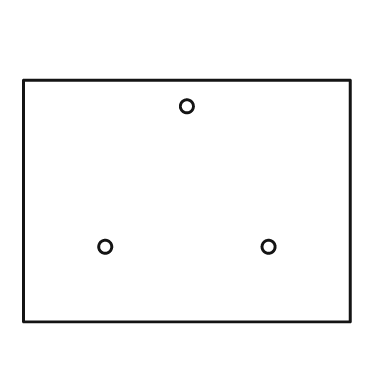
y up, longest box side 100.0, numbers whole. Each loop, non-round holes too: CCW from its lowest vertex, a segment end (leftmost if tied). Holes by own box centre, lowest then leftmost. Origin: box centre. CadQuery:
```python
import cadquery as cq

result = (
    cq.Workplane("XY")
    .moveTo(-50.0, -37.0)
    .lineTo(50.0, -37.0)
    .lineTo(50.0, 37.0)
    .lineTo(-50.0, 37.0)
    .close()
    .moveTo(-25.0, -14.0)
    .circle(2.0)
    .moveTo(25.0, -14.0)
    .circle(2.0)
    .moveTo(0.0, 29.0)
    .circle(2.0)
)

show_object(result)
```